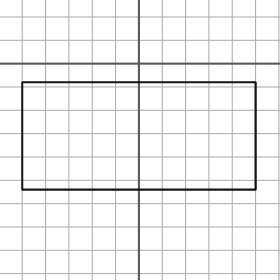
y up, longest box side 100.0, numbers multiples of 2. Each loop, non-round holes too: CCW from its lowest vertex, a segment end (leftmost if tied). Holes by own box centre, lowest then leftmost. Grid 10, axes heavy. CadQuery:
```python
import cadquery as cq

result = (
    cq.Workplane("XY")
    .moveTo(-50.0, -54.0)
    .lineTo(50.0, -54.0)
    .lineTo(50.0, -8.0)
    .lineTo(-50.0, -8.0)
    .close()
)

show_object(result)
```